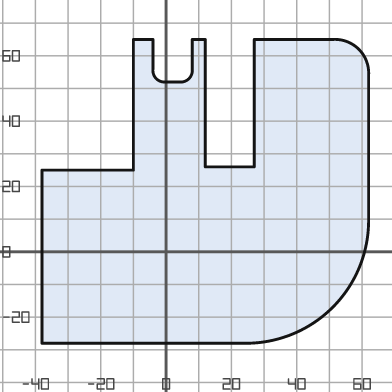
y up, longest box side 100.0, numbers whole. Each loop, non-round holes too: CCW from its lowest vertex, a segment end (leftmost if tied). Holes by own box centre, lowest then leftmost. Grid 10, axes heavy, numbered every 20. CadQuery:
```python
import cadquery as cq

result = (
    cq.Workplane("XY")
    .moveTo(-38.0, -28.0)
    .lineTo(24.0, -28.0)
    .threePointArc((51.0, -17.0), (62.0, 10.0))
    .lineTo(62.0, 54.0)
    .threePointArc((59.0, 62.0), (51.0, 65.0))
    .lineTo(27.0, 65.0)
    .lineTo(27.0, 26.0)
    .lineTo(12.0, 26.0)
    .lineTo(12.0, 65.0)
    .lineTo(8.0, 65.0)
    .lineTo(8.0, 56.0)
    .threePointArc((7.0, 53.0), (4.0, 52.0))
    .lineTo(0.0, 52.0)
    .threePointArc((-3.0, 53.0), (-4.0, 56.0))
    .lineTo(-4.0, 65.0)
    .lineTo(-10.0, 65.0)
    .lineTo(-10.0, 25.0)
    .lineTo(-38.0, 25.0)
    .close()
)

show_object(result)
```